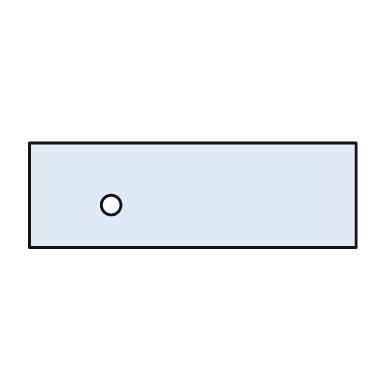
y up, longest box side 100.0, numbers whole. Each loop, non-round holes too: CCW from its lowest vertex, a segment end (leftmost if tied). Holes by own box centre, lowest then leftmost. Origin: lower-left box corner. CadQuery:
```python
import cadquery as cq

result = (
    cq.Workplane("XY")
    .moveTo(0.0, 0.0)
    .lineTo(100.0, 0.0)
    .lineTo(100.0, 32.0)
    .lineTo(0.0, 32.0)
    .close()
    .moveTo(25.0, 13.0)
    .circle(3.0)
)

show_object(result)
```